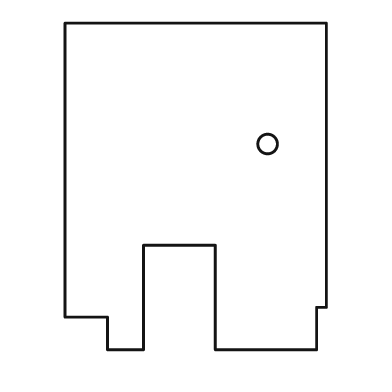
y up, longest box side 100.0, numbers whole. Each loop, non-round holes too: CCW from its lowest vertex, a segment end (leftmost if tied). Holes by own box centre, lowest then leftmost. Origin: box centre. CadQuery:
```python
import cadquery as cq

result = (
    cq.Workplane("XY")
    .moveTo(-27.0, -50.0)
    .lineTo(-16.0, -50.0)
    .lineTo(-16.0, -18.0)
    .lineTo(6.0, -18.0)
    .lineTo(6.0, -50.0)
    .lineTo(37.0, -50.0)
    .lineTo(37.0, -37.0)
    .lineTo(40.0, -37.0)
    .lineTo(40.0, 50.0)
    .lineTo(-40.0, 50.0)
    .lineTo(-40.0, -40.0)
    .lineTo(-27.0, -40.0)
    .close()
    .moveTo(22.0, 13.0)
    .circle(3.0)
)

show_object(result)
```